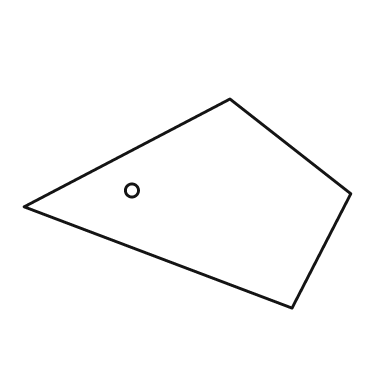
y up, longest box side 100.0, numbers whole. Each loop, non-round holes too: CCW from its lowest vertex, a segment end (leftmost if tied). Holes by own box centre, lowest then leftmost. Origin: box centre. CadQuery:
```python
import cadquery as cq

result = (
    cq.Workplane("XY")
    .moveTo(32.0, -32.0)
    .lineTo(50.0, 3.0)
    .lineTo(13.0, 32.0)
    .lineTo(-50.0, -1.0)
    .close()
    .moveTo(-17.0, 4.0)
    .circle(2.0)
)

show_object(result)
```